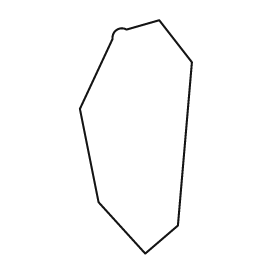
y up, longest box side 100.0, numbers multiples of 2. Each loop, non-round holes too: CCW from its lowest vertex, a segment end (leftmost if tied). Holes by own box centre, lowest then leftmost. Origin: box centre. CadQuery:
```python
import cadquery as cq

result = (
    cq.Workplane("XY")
    .moveTo(4.0, -50.0)
    .lineTo(18.0, -38.0)
    .lineTo(24.0, 32.0)
    .lineTo(10.0, 50.0)
    .lineTo(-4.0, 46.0)
    .threePointArc((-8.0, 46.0), (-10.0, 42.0))
    .lineTo(-24.0, 12.0)
    .lineTo(-16.0, -28.0)
    .close()
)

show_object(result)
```